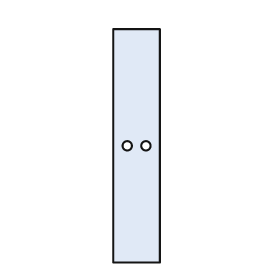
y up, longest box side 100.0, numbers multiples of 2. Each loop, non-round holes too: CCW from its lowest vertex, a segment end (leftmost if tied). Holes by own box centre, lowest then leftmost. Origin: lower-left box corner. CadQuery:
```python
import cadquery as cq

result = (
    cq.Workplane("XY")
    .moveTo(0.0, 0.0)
    .lineTo(20.0, 0.0)
    .lineTo(20.0, 100.0)
    .lineTo(0.0, 100.0)
    .close()
    .moveTo(6.0, 50.0)
    .circle(2.0)
    .moveTo(14.0, 50.0)
    .circle(2.0)
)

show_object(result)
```